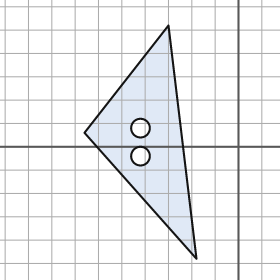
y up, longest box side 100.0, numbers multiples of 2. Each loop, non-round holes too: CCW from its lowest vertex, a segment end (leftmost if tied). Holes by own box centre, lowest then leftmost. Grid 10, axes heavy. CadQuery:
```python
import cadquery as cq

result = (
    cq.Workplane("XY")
    .moveTo(-18.0, -48.0)
    .lineTo(-30.0, 52.0)
    .lineTo(-66.0, 6.0)
    .close()
    .moveTo(-42.0, -4.0)
    .circle(4.0)
    .moveTo(-42.0, 8.0)
    .circle(4.0)
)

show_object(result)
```